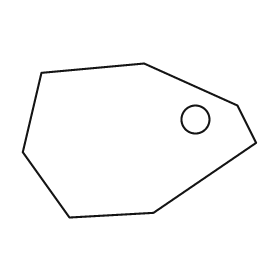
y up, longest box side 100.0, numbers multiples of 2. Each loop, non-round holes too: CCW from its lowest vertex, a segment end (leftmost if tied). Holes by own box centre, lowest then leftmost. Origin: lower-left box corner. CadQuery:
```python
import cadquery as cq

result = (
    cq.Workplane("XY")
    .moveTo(20.0, 0.0)
    .lineTo(56.0, 2.0)
    .lineTo(100.0, 32.0)
    .lineTo(92.0, 48.0)
    .lineTo(52.0, 66.0)
    .lineTo(8.0, 62.0)
    .lineTo(0.0, 28.0)
    .close()
    .moveTo(74.0, 42.0)
    .circle(6.0)
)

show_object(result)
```